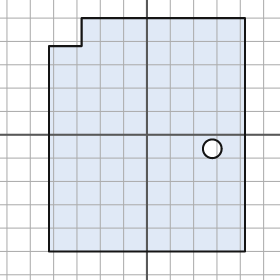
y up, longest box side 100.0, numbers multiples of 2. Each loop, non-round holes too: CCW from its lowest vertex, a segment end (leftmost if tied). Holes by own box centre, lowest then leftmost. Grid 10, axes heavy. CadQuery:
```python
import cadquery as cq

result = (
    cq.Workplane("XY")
    .moveTo(-42.0, -50.0)
    .lineTo(42.0, -50.0)
    .lineTo(42.0, 50.0)
    .lineTo(-28.0, 50.0)
    .lineTo(-28.0, 38.0)
    .lineTo(-42.0, 38.0)
    .close()
    .moveTo(28.0, -6.0)
    .circle(4.0)
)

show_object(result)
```